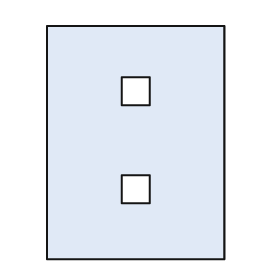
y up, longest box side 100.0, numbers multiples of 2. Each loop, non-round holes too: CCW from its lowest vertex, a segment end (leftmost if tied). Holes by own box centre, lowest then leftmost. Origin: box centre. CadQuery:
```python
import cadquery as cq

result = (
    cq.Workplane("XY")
    .moveTo(-38.0, -50.0)
    .lineTo(38.0, -50.0)
    .lineTo(38.0, 50.0)
    .lineTo(-38.0, 50.0)
    .close()
    .moveTo(-6.0, -26.0)
    .lineTo(6.0, -26.0)
    .lineTo(6.0, -14.0)
    .lineTo(-6.0, -14.0)
    .close()
    .moveTo(-6.0, 16.0)
    .lineTo(6.0, 16.0)
    .lineTo(6.0, 28.0)
    .lineTo(-6.0, 28.0)
    .close()
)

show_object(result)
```